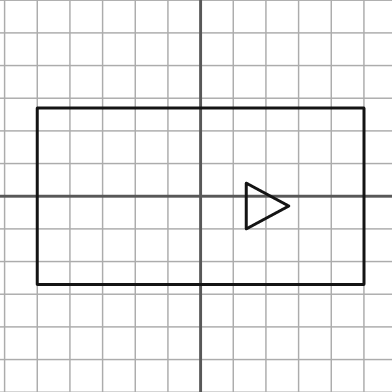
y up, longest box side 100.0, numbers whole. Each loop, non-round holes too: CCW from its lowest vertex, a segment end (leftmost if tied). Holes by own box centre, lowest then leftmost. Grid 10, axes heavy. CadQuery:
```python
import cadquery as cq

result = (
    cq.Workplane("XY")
    .moveTo(-50.0, -27.0)
    .lineTo(50.0, -27.0)
    .lineTo(50.0, 27.0)
    .lineTo(-50.0, 27.0)
    .close()
    .moveTo(14.0, -10.0)
    .lineTo(27.0, -3.0)
    .lineTo(14.0, 4.0)
    .close()
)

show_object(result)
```